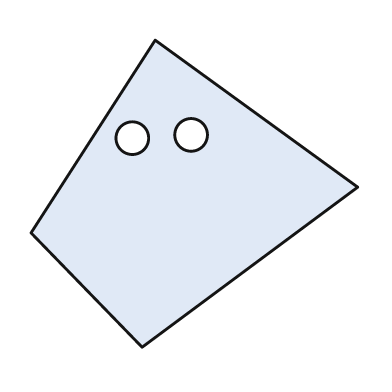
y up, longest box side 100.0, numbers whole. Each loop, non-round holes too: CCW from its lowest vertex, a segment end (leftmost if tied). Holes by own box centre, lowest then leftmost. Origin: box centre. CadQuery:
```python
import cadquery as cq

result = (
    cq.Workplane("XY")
    .moveTo(-16.0, -47.0)
    .lineTo(50.0, 2.0)
    .lineTo(-12.0, 47.0)
    .lineTo(-50.0, -12.0)
    .close()
    .moveTo(-19.0, 17.0)
    .circle(5.0)
    .moveTo(-1.0, 18.0)
    .circle(5.0)
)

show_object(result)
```